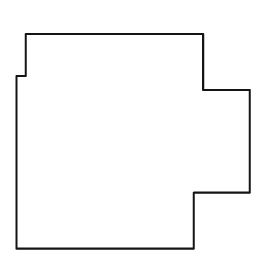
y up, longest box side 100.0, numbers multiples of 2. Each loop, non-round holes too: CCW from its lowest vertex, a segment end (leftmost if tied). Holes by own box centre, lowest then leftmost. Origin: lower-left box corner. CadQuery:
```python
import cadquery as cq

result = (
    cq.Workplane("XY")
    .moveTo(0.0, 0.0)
    .lineTo(76.0, 0.0)
    .lineTo(76.0, 24.0)
    .lineTo(100.0, 24.0)
    .lineTo(100.0, 68.0)
    .lineTo(80.0, 68.0)
    .lineTo(80.0, 92.0)
    .lineTo(4.0, 92.0)
    .lineTo(4.0, 74.0)
    .lineTo(0.0, 74.0)
    .close()
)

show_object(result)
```